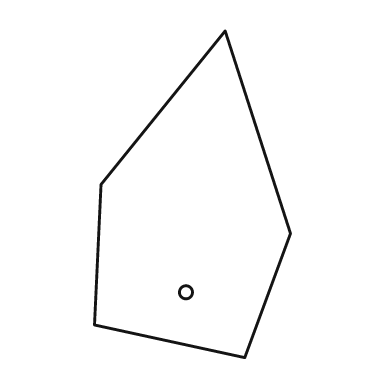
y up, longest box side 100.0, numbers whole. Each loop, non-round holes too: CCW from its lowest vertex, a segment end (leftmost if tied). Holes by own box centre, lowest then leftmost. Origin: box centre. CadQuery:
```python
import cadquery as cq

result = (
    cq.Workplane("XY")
    .moveTo(16.0, -50.0)
    .lineTo(30.0, -12.0)
    .lineTo(10.0, 50.0)
    .lineTo(-28.0, 3.0)
    .lineTo(-30.0, -40.0)
    .close()
    .moveTo(-2.0, -30.0)
    .circle(2.0)
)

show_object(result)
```